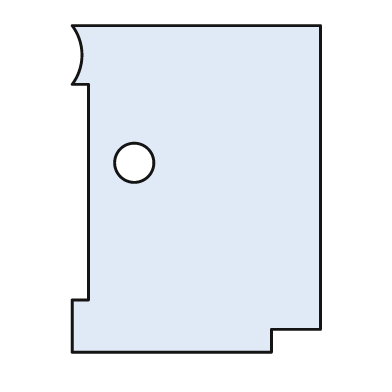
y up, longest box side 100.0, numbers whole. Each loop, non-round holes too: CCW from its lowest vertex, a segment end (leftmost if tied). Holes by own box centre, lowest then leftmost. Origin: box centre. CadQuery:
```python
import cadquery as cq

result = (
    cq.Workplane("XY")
    .moveTo(-38.0, -50.0)
    .lineTo(23.0, -50.0)
    .lineTo(23.0, -43.0)
    .lineTo(38.0, -43.0)
    .lineTo(38.0, 50.0)
    .lineTo(-38.0, 50.0)
    .threePointArc((-35.0, 41.0), (-38.0, 32.0))
    .lineTo(-33.0, 32.0)
    .lineTo(-33.0, -34.0)
    .lineTo(-38.0, -34.0)
    .close()
    .moveTo(-19.0, 8.0)
    .circle(6.0)
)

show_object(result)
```